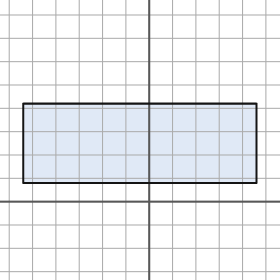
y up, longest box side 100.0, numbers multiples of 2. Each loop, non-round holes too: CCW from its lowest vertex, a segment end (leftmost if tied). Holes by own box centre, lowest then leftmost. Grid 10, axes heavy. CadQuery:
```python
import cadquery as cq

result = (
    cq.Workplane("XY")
    .moveTo(-54.0, 8.0)
    .lineTo(46.0, 8.0)
    .lineTo(46.0, 42.0)
    .lineTo(-54.0, 42.0)
    .close()
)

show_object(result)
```